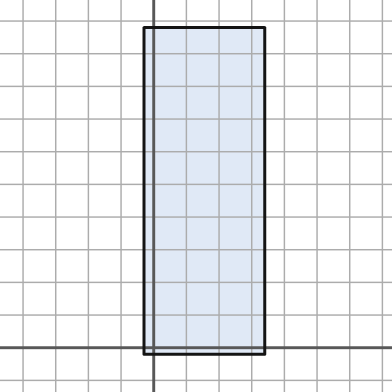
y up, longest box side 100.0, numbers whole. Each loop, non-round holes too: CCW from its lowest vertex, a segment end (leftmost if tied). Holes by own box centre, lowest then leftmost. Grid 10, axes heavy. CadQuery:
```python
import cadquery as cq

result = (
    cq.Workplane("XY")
    .moveTo(-3.0, -2.0)
    .lineTo(34.0, -2.0)
    .lineTo(34.0, 98.0)
    .lineTo(-3.0, 98.0)
    .close()
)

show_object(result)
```